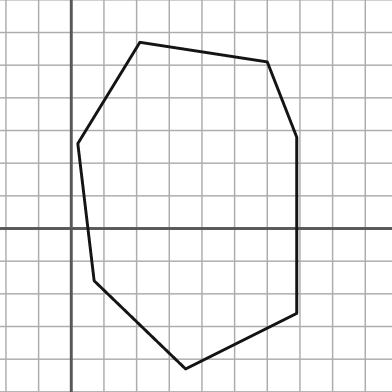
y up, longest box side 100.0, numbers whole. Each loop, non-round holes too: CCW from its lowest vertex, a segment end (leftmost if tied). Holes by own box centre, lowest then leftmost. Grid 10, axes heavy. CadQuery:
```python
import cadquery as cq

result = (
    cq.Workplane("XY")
    .moveTo(35.0, -43.0)
    .lineTo(69.0, -26.0)
    .lineTo(69.0, 28.0)
    .lineTo(60.0, 51.0)
    .lineTo(21.0, 57.0)
    .lineTo(2.0, 26.0)
    .lineTo(7.0, -16.0)
    .close()
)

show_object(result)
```